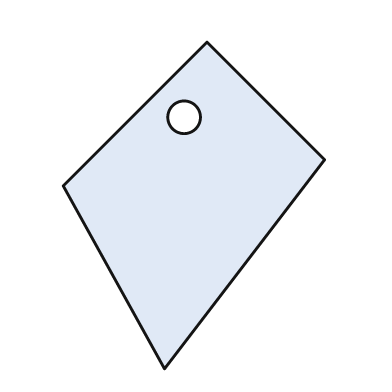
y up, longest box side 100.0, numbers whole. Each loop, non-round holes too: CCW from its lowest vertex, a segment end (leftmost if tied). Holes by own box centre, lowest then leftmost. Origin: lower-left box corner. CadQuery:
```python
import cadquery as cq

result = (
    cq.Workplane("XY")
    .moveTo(31.0, 0.0)
    .lineTo(80.0, 64.0)
    .lineTo(44.0, 100.0)
    .lineTo(0.0, 56.0)
    .close()
    .moveTo(37.0, 77.0)
    .circle(5.0)
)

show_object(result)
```